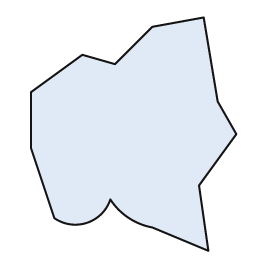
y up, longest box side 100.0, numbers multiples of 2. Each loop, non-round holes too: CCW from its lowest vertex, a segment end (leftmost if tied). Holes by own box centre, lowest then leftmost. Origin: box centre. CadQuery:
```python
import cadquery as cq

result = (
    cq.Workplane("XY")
    .moveTo(32.0, -50.0)
    .lineTo(28.0, -22.0)
    .lineTo(44.0, 0.0)
    .lineTo(36.0, 14.0)
    .lineTo(30.0, 50.0)
    .lineTo(8.0, 46.0)
    .lineTo(-8.0, 30.0)
    .lineTo(-22.0, 34.0)
    .lineTo(-44.0, 18.0)
    .lineTo(-44.0, -6.0)
    .lineTo(-34.0, -36.0)
    .threePointArc((-20.0, -38.0), (-10.0, -28.0))
    .threePointArc((-2.0, -36.0), (8.0, -40.0))
    .close()
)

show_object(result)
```